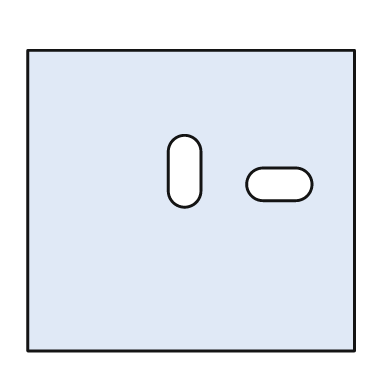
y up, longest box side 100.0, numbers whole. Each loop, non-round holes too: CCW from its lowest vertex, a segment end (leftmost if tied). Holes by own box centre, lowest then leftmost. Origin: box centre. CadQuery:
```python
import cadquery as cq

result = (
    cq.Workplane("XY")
    .moveTo(-50.0, -46.0)
    .lineTo(50.0, -46.0)
    .lineTo(50.0, 46.0)
    .lineTo(-50.0, 46.0)
    .close()
    .moveTo(22.0, 0.0)
    .lineTo(32.0, 0.0)
    .threePointArc((37.0, 5.0), (32.0, 10.0))
    .lineTo(22.0, 10.0)
    .threePointArc((17.0, 5.0), (22.0, 0.0))
    .close()
    .moveTo(-7.0, 3.0)
    .threePointArc((-2.0, -2.0), (3.0, 3.0))
    .lineTo(3.0, 15.0)
    .threePointArc((-2.0, 20.0), (-7.0, 15.0))
    .close()
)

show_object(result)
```